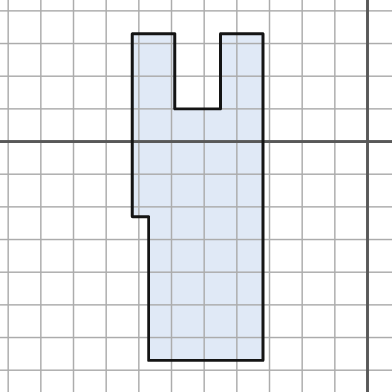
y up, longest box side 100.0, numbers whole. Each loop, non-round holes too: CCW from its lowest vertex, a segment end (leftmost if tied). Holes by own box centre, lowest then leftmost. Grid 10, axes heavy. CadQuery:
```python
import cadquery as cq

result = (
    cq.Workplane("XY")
    .moveTo(-67.0, -67.0)
    .lineTo(-32.0, -67.0)
    .lineTo(-32.0, 33.0)
    .lineTo(-45.0, 33.0)
    .lineTo(-45.0, 10.0)
    .lineTo(-59.0, 10.0)
    .lineTo(-59.0, 33.0)
    .lineTo(-72.0, 33.0)
    .lineTo(-72.0, -23.0)
    .lineTo(-67.0, -23.0)
    .close()
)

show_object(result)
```